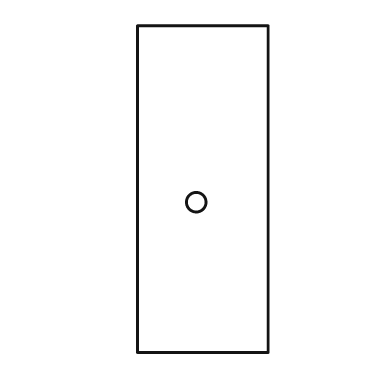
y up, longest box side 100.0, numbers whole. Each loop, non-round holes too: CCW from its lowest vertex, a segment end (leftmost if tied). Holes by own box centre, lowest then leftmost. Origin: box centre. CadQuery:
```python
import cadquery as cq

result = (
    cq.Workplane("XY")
    .moveTo(-20.0, -50.0)
    .lineTo(20.0, -50.0)
    .lineTo(20.0, 50.0)
    .lineTo(-20.0, 50.0)
    .close()
    .moveTo(-2.0, -4.0)
    .circle(3.0)
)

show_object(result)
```